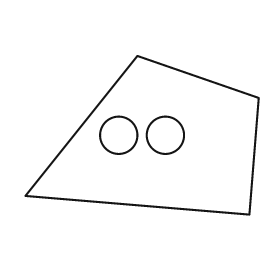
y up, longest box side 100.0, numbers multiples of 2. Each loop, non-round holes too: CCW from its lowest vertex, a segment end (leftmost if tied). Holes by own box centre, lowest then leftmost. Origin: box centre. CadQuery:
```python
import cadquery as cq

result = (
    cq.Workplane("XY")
    .moveTo(46.0, -34.0)
    .lineTo(50.0, 16.0)
    .lineTo(-2.0, 34.0)
    .lineTo(-50.0, -26.0)
    .close()
    .moveTo(-10.0, 0.0)
    .circle(8.0)
    .moveTo(10.0, 0.0)
    .circle(8.0)
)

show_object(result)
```